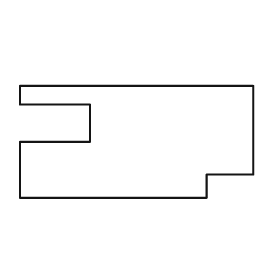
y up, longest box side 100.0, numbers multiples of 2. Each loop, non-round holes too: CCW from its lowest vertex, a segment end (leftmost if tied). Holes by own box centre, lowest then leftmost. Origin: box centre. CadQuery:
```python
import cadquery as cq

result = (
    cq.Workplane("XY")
    .moveTo(-50.0, -24.0)
    .lineTo(30.0, -24.0)
    .lineTo(30.0, -14.0)
    .lineTo(50.0, -14.0)
    .lineTo(50.0, 24.0)
    .lineTo(-50.0, 24.0)
    .lineTo(-50.0, 16.0)
    .lineTo(-20.0, 16.0)
    .lineTo(-20.0, 0.0)
    .lineTo(-50.0, 0.0)
    .close()
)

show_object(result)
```